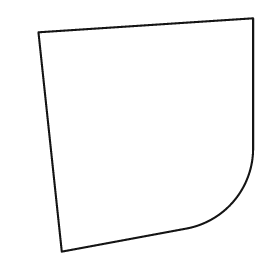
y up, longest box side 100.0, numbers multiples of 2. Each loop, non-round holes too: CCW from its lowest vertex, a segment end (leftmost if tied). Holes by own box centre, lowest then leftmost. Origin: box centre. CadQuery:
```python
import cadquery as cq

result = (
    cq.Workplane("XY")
    .moveTo(-36.0, -50.0)
    .lineTo(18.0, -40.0)
    .threePointArc((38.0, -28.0), (46.0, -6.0))
    .lineTo(46.0, 50.0)
    .lineTo(-46.0, 44.0)
    .close()
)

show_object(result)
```